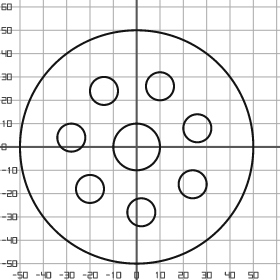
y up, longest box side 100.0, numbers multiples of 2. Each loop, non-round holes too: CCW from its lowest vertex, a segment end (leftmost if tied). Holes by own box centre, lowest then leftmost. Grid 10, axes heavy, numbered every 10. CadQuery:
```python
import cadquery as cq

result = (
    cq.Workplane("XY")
    .moveTo(0.0, 0.0)
    .circle(50.0)
    .moveTo(2.0, -28.0)
    .circle(6.0)
    .moveTo(-20.0, -18.0)
    .circle(6.0)
    .moveTo(24.0, -16.0)
    .circle(6.0)
    .moveTo(0.0, 0.0)
    .circle(10.0)
    .moveTo(-28.0, 4.0)
    .circle(6.0)
    .moveTo(26.0, 8.0)
    .circle(6.0)
    .moveTo(-14.0, 24.0)
    .circle(6.0)
    .moveTo(10.0, 26.0)
    .circle(6.0)
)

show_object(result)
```